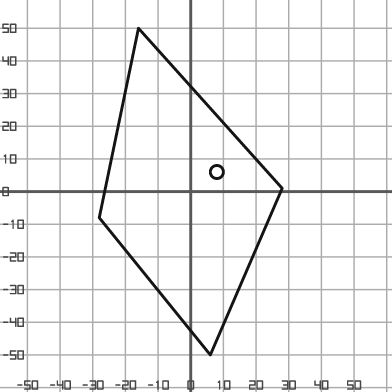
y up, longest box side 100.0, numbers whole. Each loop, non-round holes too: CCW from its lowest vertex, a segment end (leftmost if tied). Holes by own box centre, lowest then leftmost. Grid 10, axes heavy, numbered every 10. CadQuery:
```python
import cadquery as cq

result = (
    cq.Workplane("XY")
    .moveTo(6.0, -50.0)
    .lineTo(28.0, 1.0)
    .lineTo(-16.0, 50.0)
    .lineTo(-28.0, -8.0)
    .close()
    .moveTo(8.0, 6.0)
    .circle(2.0)
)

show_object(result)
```